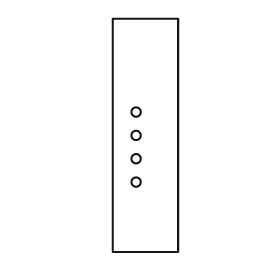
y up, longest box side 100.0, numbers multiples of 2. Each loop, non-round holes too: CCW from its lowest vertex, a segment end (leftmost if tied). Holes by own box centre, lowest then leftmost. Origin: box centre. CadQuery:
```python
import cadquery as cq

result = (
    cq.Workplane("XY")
    .moveTo(-14.0, -50.0)
    .lineTo(14.0, -50.0)
    .lineTo(14.0, 50.0)
    .lineTo(-14.0, 50.0)
    .close()
    .moveTo(-4.0, -20.0)
    .circle(2.0)
    .moveTo(-4.0, -10.0)
    .circle(2.0)
    .moveTo(-4.0, 0.0)
    .circle(2.0)
    .moveTo(-4.0, 10.0)
    .circle(2.0)
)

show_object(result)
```